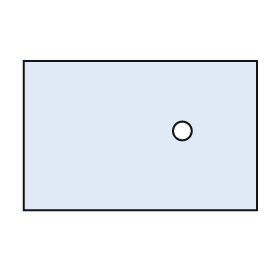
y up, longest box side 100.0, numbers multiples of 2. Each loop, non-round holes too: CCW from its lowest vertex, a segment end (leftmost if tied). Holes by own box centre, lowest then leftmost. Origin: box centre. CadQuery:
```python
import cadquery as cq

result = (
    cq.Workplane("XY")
    .moveTo(-50.0, -32.0)
    .lineTo(50.0, -32.0)
    .lineTo(50.0, 32.0)
    .lineTo(-50.0, 32.0)
    .close()
    .moveTo(18.0, 2.0)
    .circle(4.0)
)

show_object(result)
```